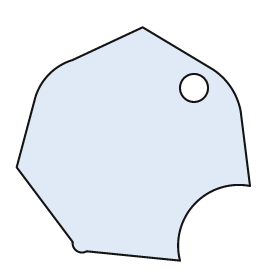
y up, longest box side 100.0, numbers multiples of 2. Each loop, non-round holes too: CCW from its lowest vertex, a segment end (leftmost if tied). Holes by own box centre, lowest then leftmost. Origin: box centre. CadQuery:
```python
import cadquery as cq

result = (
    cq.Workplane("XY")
    .moveTo(20.0, -50.0)
    .threePointArc((26.0, -26.0), (50.0, -18.0))
    .lineTo(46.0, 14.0)
    .threePointArc((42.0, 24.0), (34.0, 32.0))
    .lineTo(4.0, 50.0)
    .lineTo(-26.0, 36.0)
    .threePointArc((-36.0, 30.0), (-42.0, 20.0))
    .lineTo(-50.0, -10.0)
    .lineTo(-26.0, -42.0)
    .threePointArc((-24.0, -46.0), (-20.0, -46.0))
    .close()
    .moveTo(26.0, 24.0)
    .circle(6.0)
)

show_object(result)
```